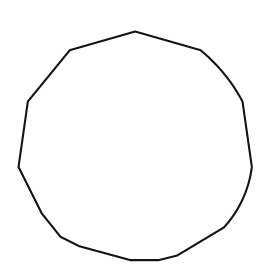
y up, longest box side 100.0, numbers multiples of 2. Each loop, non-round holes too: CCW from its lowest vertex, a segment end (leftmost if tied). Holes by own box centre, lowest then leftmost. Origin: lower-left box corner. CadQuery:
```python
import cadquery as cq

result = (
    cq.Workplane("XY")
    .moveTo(48.0, 0.0)
    .lineTo(60.0, 0.0)
    .lineTo(68.0, 2.0)
    .lineTo(88.0, 14.0)
    .threePointArc((96.0, 26.0), (100.0, 40.0))
    .lineTo(96.0, 68.0)
    .threePointArc((88.0, 80.0), (78.0, 90.0))
    .lineTo(50.0, 98.0)
    .lineTo(22.0, 90.0)
    .lineTo(4.0, 68.0)
    .lineTo(0.0, 40.0)
    .lineTo(10.0, 20.0)
    .lineTo(18.0, 10.0)
    .lineTo(26.0, 6.0)
    .close()
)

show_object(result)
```